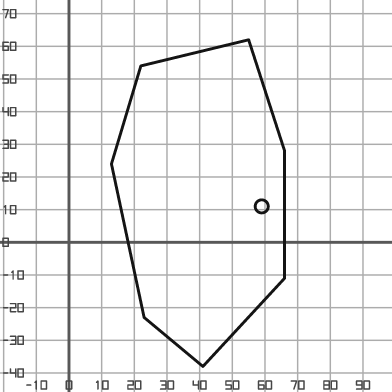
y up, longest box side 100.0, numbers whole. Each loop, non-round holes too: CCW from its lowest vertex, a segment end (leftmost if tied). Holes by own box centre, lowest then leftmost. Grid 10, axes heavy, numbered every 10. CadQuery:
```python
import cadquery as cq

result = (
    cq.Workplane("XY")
    .moveTo(41.0, -38.0)
    .lineTo(66.0, -11.0)
    .lineTo(66.0, 28.0)
    .lineTo(55.0, 62.0)
    .lineTo(22.0, 54.0)
    .lineTo(13.0, 24.0)
    .lineTo(23.0, -23.0)
    .close()
    .moveTo(59.0, 11.0)
    .circle(2.0)
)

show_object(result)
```